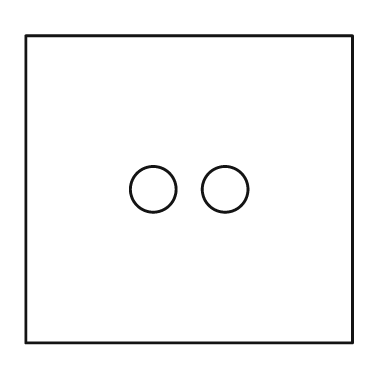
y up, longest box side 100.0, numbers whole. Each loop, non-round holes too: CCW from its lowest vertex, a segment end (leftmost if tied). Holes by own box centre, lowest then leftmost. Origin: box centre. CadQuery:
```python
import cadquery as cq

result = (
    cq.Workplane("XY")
    .moveTo(-50.0, -47.0)
    .lineTo(50.0, -47.0)
    .lineTo(50.0, 47.0)
    .lineTo(-50.0, 47.0)
    .close()
    .moveTo(-11.0, 0.0)
    .circle(7.0)
    .moveTo(11.0, 0.0)
    .circle(7.0)
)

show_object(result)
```